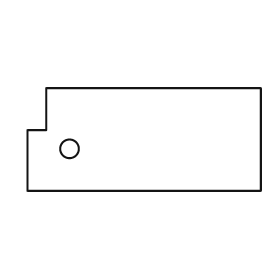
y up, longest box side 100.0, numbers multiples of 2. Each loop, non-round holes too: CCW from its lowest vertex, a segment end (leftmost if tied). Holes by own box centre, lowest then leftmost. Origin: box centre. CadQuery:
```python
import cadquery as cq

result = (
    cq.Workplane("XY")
    .moveTo(-50.0, -22.0)
    .lineTo(50.0, -22.0)
    .lineTo(50.0, 22.0)
    .lineTo(-42.0, 22.0)
    .lineTo(-42.0, 4.0)
    .lineTo(-50.0, 4.0)
    .close()
    .moveTo(-32.0, -4.0)
    .circle(4.0)
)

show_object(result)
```